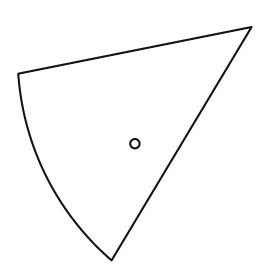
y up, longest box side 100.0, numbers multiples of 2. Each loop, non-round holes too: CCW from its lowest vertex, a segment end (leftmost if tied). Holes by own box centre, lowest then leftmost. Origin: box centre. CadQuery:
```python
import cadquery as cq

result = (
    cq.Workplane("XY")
    .moveTo(-10.0, -50.0)
    .lineTo(50.0, 50.0)
    .lineTo(-50.0, 30.0)
    .threePointArc((-38.0, -14.0), (-10.0, -50.0))
    .close()
    .moveTo(0.0, 0.0)
    .circle(2.0)
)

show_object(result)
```